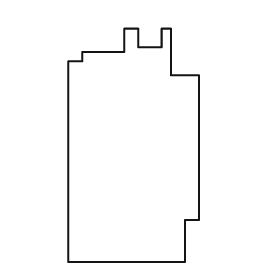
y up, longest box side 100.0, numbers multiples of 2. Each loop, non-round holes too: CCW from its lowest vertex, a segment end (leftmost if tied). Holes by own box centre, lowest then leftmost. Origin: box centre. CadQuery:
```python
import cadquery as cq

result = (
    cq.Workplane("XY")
    .moveTo(-28.0, -50.0)
    .lineTo(22.0, -50.0)
    .lineTo(22.0, -32.0)
    .lineTo(28.0, -32.0)
    .lineTo(28.0, 30.0)
    .lineTo(16.0, 30.0)
    .lineTo(16.0, 50.0)
    .lineTo(12.0, 50.0)
    .lineTo(12.0, 42.0)
    .lineTo(2.0, 42.0)
    .lineTo(2.0, 50.0)
    .lineTo(-4.0, 50.0)
    .lineTo(-4.0, 40.0)
    .lineTo(-22.0, 40.0)
    .lineTo(-22.0, 36.0)
    .lineTo(-28.0, 36.0)
    .close()
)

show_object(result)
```